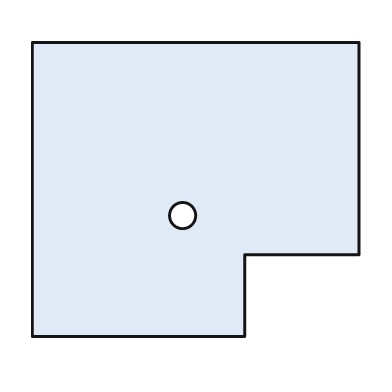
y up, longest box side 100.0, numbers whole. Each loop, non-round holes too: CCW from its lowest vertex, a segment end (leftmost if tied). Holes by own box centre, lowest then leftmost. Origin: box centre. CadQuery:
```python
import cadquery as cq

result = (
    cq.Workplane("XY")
    .moveTo(-50.0, -45.0)
    .lineTo(15.0, -45.0)
    .lineTo(15.0, -20.0)
    .lineTo(50.0, -20.0)
    .lineTo(50.0, 45.0)
    .lineTo(-50.0, 45.0)
    .close()
    .moveTo(-4.0, -8.0)
    .circle(4.0)
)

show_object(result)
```